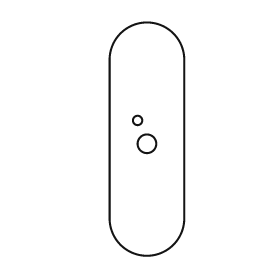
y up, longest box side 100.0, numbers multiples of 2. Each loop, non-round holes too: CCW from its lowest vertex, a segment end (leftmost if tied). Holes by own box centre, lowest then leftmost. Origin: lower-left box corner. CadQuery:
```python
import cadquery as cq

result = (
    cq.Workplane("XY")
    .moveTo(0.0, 16.0)
    .threePointArc((16.0, 0.0), (32.0, 16.0))
    .lineTo(32.0, 84.0)
    .threePointArc((16.0, 100.0), (0.0, 84.0))
    .close()
    .moveTo(16.0, 48.0)
    .circle(4.0)
    .moveTo(12.0, 58.0)
    .circle(2.0)
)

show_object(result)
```